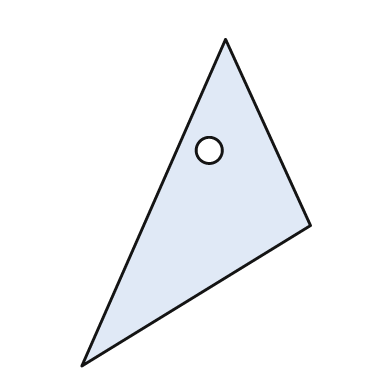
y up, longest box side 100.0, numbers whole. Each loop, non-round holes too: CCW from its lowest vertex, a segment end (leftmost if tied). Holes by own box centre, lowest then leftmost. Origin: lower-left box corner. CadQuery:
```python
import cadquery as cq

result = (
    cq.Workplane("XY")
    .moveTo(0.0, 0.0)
    .lineTo(70.0, 43.0)
    .lineTo(44.0, 100.0)
    .close()
    .moveTo(39.0, 66.0)
    .circle(4.0)
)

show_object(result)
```